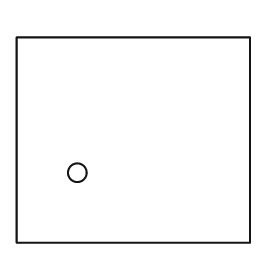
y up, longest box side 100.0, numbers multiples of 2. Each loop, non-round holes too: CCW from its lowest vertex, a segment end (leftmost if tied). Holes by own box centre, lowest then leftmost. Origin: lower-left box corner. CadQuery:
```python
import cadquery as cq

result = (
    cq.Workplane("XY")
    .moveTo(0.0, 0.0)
    .lineTo(100.0, 0.0)
    .lineTo(100.0, 88.0)
    .lineTo(0.0, 88.0)
    .close()
    .moveTo(26.0, 30.0)
    .circle(4.0)
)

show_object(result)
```